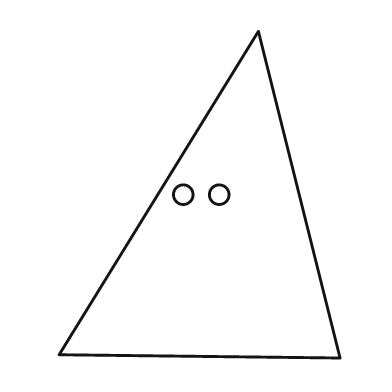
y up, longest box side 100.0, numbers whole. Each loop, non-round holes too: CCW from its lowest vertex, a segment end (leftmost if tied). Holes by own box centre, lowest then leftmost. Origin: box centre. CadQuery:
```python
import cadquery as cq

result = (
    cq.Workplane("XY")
    .moveTo(43.0, -50.0)
    .lineTo(18.0, 50.0)
    .lineTo(-43.0, -49.0)
    .close()
    .moveTo(-5.0, 0.0)
    .circle(3.0)
    .moveTo(6.0, 0.0)
    .circle(3.0)
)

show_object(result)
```